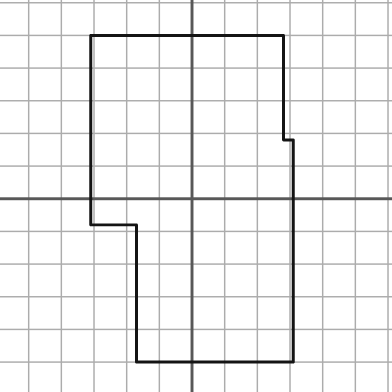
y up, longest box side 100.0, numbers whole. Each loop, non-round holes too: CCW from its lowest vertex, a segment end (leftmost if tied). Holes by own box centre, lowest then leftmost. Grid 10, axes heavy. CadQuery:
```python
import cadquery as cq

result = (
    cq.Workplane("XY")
    .moveTo(-17.0, -50.0)
    .lineTo(31.0, -50.0)
    .lineTo(31.0, 18.0)
    .lineTo(28.0, 18.0)
    .lineTo(28.0, 50.0)
    .lineTo(-31.0, 50.0)
    .lineTo(-31.0, -8.0)
    .lineTo(-17.0, -8.0)
    .close()
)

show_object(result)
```